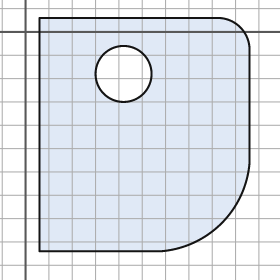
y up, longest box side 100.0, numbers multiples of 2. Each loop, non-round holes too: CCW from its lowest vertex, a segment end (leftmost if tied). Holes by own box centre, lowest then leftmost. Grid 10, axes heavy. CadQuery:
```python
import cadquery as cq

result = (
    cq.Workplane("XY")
    .moveTo(6.0, -94.0)
    .lineTo(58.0, -94.0)
    .threePointArc((84.0, -82.0), (96.0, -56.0))
    .lineTo(96.0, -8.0)
    .threePointArc((92.0, 2.0), (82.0, 6.0))
    .lineTo(6.0, 6.0)
    .close()
    .moveTo(42.0, -18.0)
    .circle(12.0)
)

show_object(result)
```